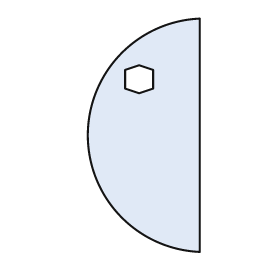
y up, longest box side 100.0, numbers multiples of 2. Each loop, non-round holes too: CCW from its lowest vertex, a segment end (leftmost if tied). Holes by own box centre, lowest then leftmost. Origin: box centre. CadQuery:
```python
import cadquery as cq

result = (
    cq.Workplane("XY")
    .moveTo(24.0, -50.0)
    .lineTo(24.0, 50.0)
    .threePointArc((-24.0, 0.0), (24.0, -50.0))
    .close()
    .moveTo(-2.0, 18.0)
    .lineTo(4.0, 20.0)
    .lineTo(4.0, 28.0)
    .lineTo(-2.0, 30.0)
    .lineTo(-8.0, 28.0)
    .lineTo(-8.0, 20.0)
    .close()
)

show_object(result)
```